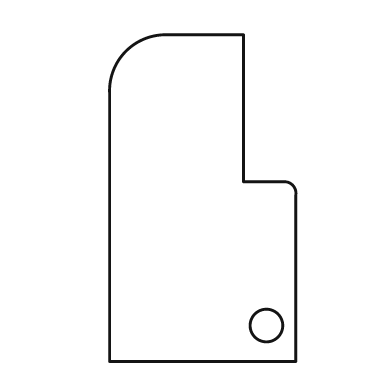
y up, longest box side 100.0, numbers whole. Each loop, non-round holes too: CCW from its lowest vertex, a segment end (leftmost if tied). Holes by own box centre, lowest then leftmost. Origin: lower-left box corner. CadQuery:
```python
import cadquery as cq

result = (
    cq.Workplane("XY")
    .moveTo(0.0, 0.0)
    .lineTo(57.0, 0.0)
    .lineTo(57.0, 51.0)
    .threePointArc((56.0, 54.0), (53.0, 55.0))
    .lineTo(41.0, 55.0)
    .lineTo(41.0, 100.0)
    .lineTo(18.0, 100.0)
    .threePointArc((5.0, 95.0), (0.0, 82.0))
    .close()
    .moveTo(48.0, 11.0)
    .circle(5.0)
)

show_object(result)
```